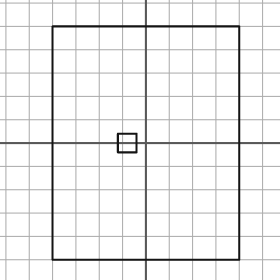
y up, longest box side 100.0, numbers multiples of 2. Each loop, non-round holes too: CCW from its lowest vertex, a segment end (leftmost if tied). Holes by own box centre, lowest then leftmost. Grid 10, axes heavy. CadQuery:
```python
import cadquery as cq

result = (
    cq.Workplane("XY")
    .moveTo(-40.0, -50.0)
    .lineTo(40.0, -50.0)
    .lineTo(40.0, 50.0)
    .lineTo(-40.0, 50.0)
    .close()
    .moveTo(-12.0, -4.0)
    .lineTo(-4.0, -4.0)
    .lineTo(-4.0, 4.0)
    .lineTo(-12.0, 4.0)
    .close()
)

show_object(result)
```